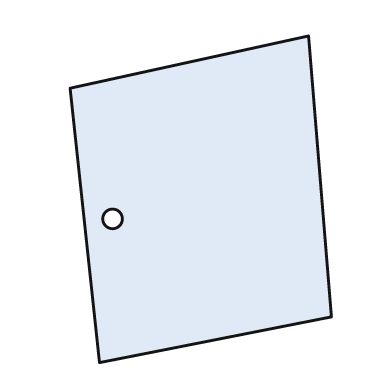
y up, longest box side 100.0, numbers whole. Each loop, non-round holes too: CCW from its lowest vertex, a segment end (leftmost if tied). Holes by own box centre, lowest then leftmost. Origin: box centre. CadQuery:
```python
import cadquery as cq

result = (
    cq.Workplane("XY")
    .moveTo(-31.0, -50.0)
    .lineTo(40.0, -36.0)
    .lineTo(33.0, 50.0)
    .lineTo(-40.0, 34.0)
    .close()
    .moveTo(-27.0, -6.0)
    .circle(3.0)
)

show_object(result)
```